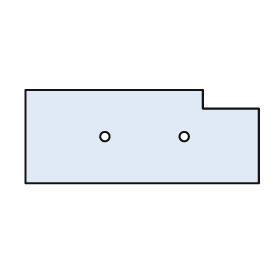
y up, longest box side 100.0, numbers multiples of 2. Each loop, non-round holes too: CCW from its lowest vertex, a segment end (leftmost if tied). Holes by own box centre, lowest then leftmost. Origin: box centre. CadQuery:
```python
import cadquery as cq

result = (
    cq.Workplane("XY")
    .moveTo(-50.0, -20.0)
    .lineTo(50.0, -20.0)
    .lineTo(50.0, 12.0)
    .lineTo(26.0, 12.0)
    .lineTo(26.0, 20.0)
    .lineTo(-50.0, 20.0)
    .close()
    .moveTo(-16.0, 0.0)
    .circle(2.0)
    .moveTo(18.0, 0.0)
    .circle(2.0)
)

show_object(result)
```